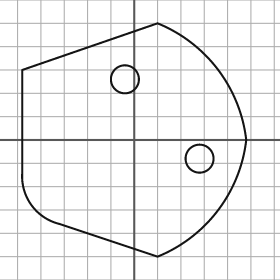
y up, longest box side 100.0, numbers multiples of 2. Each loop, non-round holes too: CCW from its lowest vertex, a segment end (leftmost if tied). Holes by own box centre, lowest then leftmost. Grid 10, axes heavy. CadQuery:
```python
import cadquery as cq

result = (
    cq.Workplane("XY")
    .moveTo(10.0, -50.0)
    .threePointArc((36.0, -30.0), (48.0, 0.0))
    .threePointArc((36.0, 30.0), (10.0, 50.0))
    .lineTo(-48.0, 30.0)
    .lineTo(-48.0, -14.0)
    .threePointArc((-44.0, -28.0), (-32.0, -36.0))
    .close()
    .moveTo(28.0, -8.0)
    .circle(6.0)
    .moveTo(-4.0, 26.0)
    .circle(6.0)
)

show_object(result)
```